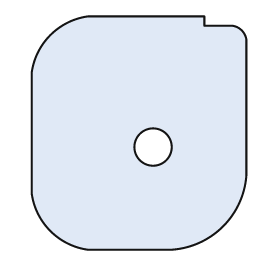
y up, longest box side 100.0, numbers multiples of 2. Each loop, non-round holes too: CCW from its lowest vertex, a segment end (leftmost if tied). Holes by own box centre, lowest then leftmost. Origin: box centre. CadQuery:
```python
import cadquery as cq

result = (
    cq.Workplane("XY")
    .moveTo(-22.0, -50.0)
    .lineTo(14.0, -50.0)
    .threePointArc((36.0, -40.0), (46.0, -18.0))
    .lineTo(46.0, 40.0)
    .threePointArc((44.0, 44.0), (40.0, 46.0))
    .lineTo(28.0, 46.0)
    .lineTo(28.0, 50.0)
    .lineTo(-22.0, 50.0)
    .threePointArc((-38.0, 42.0), (-46.0, 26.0))
    .lineTo(-46.0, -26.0)
    .threePointArc((-38.0, -42.0), (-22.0, -50.0))
    .close()
    .moveTo(6.0, -6.0)
    .circle(8.0)
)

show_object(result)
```